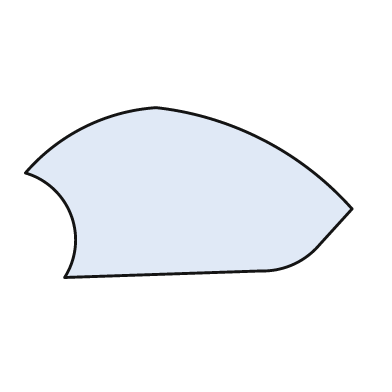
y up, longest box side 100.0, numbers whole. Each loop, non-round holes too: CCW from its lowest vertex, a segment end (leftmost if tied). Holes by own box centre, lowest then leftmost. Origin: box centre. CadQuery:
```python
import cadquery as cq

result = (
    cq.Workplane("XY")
    .moveTo(-38.0, -26.0)
    .lineTo(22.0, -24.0)
    .threePointArc((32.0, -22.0), (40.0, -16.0))
    .lineTo(50.0, -5.0)
    .threePointArc((23.0, 16.0), (-10.0, 26.0))
    .threePointArc((-32.0, 20.0), (-50.0, 6.0))
    .threePointArc((-36.0, -7.0), (-38.0, -26.0))
    .close()
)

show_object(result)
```